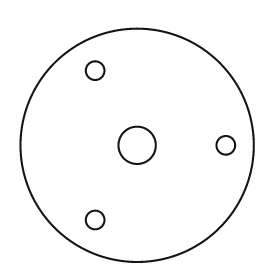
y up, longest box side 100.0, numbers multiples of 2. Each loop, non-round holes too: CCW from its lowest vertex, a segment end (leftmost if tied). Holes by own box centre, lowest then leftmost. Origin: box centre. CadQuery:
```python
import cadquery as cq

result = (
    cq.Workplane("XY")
    .moveTo(0.0, 0.0)
    .circle(50.0)
    .moveTo(-18.0, -32.0)
    .circle(4.0)
    .moveTo(0.0, 0.0)
    .circle(8.0)
    .moveTo(38.0, 0.0)
    .circle(4.0)
    .moveTo(-18.0, 32.0)
    .circle(4.0)
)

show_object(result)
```